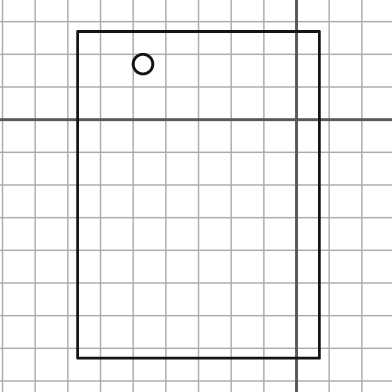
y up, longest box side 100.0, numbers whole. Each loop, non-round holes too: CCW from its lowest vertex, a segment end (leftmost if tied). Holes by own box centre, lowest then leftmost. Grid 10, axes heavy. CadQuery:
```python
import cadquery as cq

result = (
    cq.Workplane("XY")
    .moveTo(-67.0, -73.0)
    .lineTo(7.0, -73.0)
    .lineTo(7.0, 27.0)
    .lineTo(-67.0, 27.0)
    .close()
    .moveTo(-47.0, 17.0)
    .circle(3.0)
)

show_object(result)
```